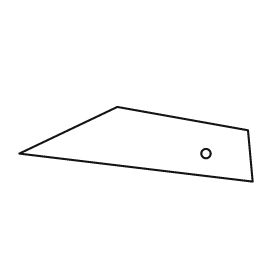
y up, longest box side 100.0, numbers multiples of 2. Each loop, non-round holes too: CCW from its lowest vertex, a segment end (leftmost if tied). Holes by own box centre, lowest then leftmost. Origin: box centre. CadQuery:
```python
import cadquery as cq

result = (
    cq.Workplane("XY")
    .moveTo(50.0, -16.0)
    .lineTo(48.0, 6.0)
    .lineTo(-8.0, 16.0)
    .lineTo(-50.0, -4.0)
    .close()
    .moveTo(30.0, -4.0)
    .circle(2.0)
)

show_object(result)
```